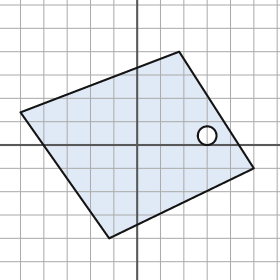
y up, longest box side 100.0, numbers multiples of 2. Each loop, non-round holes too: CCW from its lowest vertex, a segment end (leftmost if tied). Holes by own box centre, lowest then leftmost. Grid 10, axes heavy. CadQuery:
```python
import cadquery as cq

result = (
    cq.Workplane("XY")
    .moveTo(-12.0, -40.0)
    .lineTo(50.0, -10.0)
    .lineTo(18.0, 40.0)
    .lineTo(-50.0, 14.0)
    .close()
    .moveTo(30.0, 4.0)
    .circle(4.0)
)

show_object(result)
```